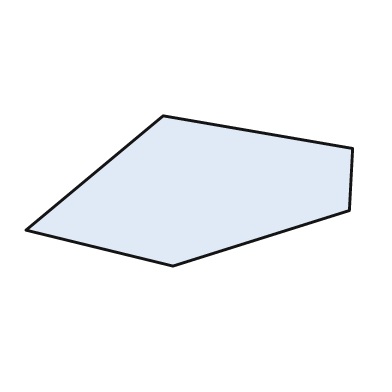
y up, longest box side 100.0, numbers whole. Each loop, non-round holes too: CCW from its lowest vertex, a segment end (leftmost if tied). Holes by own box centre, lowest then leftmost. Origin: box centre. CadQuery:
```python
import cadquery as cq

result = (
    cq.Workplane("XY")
    .moveTo(-5.0, -23.0)
    .lineTo(49.0, -6.0)
    .lineTo(50.0, 13.0)
    .lineTo(-8.0, 23.0)
    .lineTo(-50.0, -12.0)
    .close()
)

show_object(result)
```